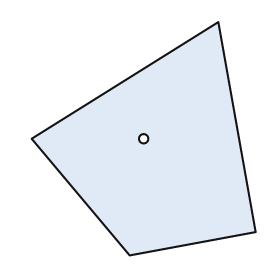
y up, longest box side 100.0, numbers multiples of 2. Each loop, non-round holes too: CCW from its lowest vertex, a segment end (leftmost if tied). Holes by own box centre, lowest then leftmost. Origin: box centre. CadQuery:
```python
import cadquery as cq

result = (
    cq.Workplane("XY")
    .moveTo(-6.0, -50.0)
    .lineTo(48.0, -40.0)
    .lineTo(32.0, 50.0)
    .lineTo(-48.0, 0.0)
    .close()
    .moveTo(0.0, 0.0)
    .circle(2.0)
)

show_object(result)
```